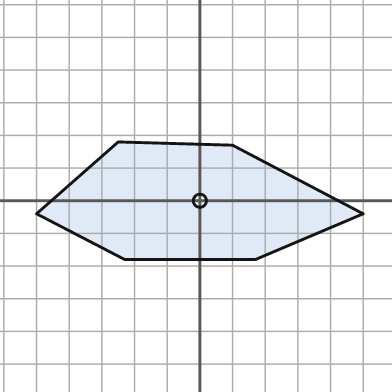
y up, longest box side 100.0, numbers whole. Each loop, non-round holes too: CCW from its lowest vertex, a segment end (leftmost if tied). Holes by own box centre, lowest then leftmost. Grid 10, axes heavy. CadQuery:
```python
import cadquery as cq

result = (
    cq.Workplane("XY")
    .moveTo(-23.0, -18.0)
    .lineTo(17.0, -18.0)
    .lineTo(50.0, -4.0)
    .lineTo(10.0, 17.0)
    .lineTo(-25.0, 18.0)
    .lineTo(-50.0, -4.0)
    .close()
    .moveTo(0.0, 0.0)
    .circle(2.0)
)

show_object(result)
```